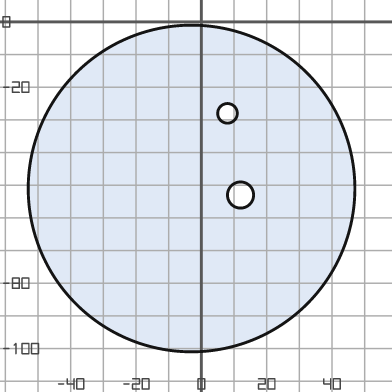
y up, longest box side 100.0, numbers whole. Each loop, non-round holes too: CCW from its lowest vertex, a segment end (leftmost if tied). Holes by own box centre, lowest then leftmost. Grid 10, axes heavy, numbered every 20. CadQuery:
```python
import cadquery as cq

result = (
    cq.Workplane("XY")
    .moveTo(-3.0, -51.0)
    .circle(50.0)
    .moveTo(12.0, -53.0)
    .circle(4.0)
    .moveTo(8.0, -28.0)
    .circle(3.0)
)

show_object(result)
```